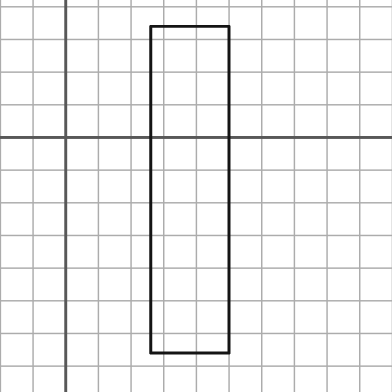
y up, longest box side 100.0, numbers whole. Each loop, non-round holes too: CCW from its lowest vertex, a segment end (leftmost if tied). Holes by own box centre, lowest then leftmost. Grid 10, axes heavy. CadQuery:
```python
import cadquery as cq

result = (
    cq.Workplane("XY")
    .moveTo(26.0, -66.0)
    .lineTo(50.0, -66.0)
    .lineTo(50.0, 34.0)
    .lineTo(26.0, 34.0)
    .close()
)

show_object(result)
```